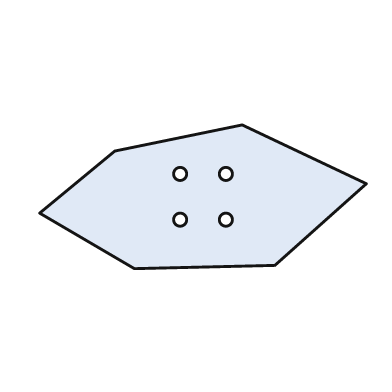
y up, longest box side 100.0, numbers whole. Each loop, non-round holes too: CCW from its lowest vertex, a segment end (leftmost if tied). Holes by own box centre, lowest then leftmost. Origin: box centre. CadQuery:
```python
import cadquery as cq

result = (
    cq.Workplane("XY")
    .moveTo(-21.0, -22.0)
    .lineTo(22.0, -21.0)
    .lineTo(50.0, 4.0)
    .lineTo(12.0, 22.0)
    .lineTo(-27.0, 14.0)
    .lineTo(-50.0, -5.0)
    .close()
    .moveTo(-7.0, -7.0)
    .circle(2.0)
    .moveTo(7.0, -7.0)
    .circle(2.0)
    .moveTo(-7.0, 7.0)
    .circle(2.0)
    .moveTo(7.0, 7.0)
    .circle(2.0)
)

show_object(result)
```